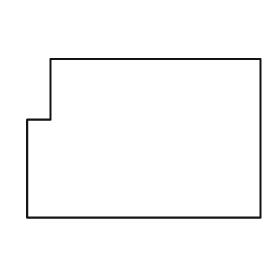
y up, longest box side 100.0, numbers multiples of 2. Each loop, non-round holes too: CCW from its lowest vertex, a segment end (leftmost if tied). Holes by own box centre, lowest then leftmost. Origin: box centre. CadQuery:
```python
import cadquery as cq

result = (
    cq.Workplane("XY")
    .moveTo(-50.0, -34.0)
    .lineTo(50.0, -34.0)
    .lineTo(50.0, 34.0)
    .lineTo(-40.0, 34.0)
    .lineTo(-40.0, 8.0)
    .lineTo(-50.0, 8.0)
    .close()
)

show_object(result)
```